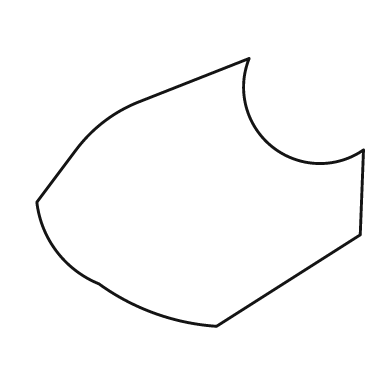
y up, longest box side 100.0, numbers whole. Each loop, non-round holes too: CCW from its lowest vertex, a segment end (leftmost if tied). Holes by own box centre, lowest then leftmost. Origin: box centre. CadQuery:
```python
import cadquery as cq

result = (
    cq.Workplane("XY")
    .moveTo(5.0, -41.0)
    .lineTo(49.0, -13.0)
    .lineTo(50.0, 13.0)
    .threePointArc((22.0, 14.0), (15.0, 41.0))
    .lineTo(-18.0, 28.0)
    .threePointArc((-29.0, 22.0), (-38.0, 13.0))
    .lineTo(-50.0, -3.0)
    .threePointArc((-44.0, -18.0), (-31.0, -28.0))
    .threePointArc((-14.0, -37.0), (5.0, -41.0))
    .close()
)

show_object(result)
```